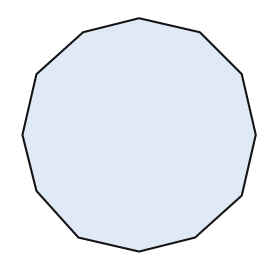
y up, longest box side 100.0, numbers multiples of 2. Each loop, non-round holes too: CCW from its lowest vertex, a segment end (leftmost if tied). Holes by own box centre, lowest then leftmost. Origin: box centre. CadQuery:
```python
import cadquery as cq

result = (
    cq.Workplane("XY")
    .moveTo(0.0, -50.0)
    .lineTo(24.0, -44.0)
    .lineTo(44.0, -26.0)
    .lineTo(50.0, 0.0)
    .lineTo(44.0, 26.0)
    .lineTo(26.0, 44.0)
    .lineTo(0.0, 50.0)
    .lineTo(-24.0, 44.0)
    .lineTo(-44.0, 26.0)
    .lineTo(-50.0, 0.0)
    .lineTo(-44.0, -24.0)
    .lineTo(-26.0, -44.0)
    .close()
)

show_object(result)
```